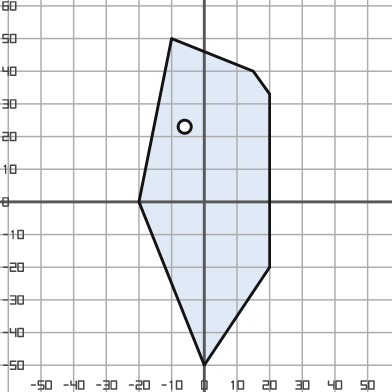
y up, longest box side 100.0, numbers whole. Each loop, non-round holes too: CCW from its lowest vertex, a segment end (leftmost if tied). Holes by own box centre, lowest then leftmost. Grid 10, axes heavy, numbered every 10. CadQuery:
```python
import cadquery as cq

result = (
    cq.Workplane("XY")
    .moveTo(0.0, -50.0)
    .lineTo(20.0, -20.0)
    .lineTo(20.0, 33.0)
    .lineTo(15.0, 40.0)
    .lineTo(-10.0, 50.0)
    .lineTo(-20.0, 0.0)
    .close()
    .moveTo(-6.0, 23.0)
    .circle(2.0)
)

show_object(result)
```